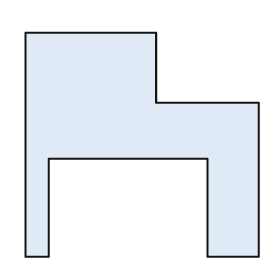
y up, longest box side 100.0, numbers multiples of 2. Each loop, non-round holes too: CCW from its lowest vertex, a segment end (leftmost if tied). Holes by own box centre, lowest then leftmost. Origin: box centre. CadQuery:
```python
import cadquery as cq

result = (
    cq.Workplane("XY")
    .moveTo(-50.0, -48.0)
    .lineTo(-40.0, -48.0)
    .lineTo(-40.0, -6.0)
    .lineTo(28.0, -6.0)
    .lineTo(28.0, -48.0)
    .lineTo(50.0, -48.0)
    .lineTo(50.0, 18.0)
    .lineTo(6.0, 18.0)
    .lineTo(6.0, 48.0)
    .lineTo(-50.0, 48.0)
    .close()
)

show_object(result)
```